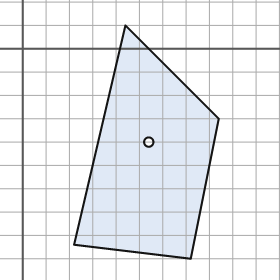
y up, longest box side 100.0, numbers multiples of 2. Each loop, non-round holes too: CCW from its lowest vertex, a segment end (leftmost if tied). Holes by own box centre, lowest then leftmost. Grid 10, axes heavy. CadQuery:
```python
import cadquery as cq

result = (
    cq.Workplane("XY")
    .moveTo(72.0, -90.0)
    .lineTo(84.0, -30.0)
    .lineTo(44.0, 10.0)
    .lineTo(22.0, -84.0)
    .close()
    .moveTo(54.0, -40.0)
    .circle(2.0)
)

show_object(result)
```